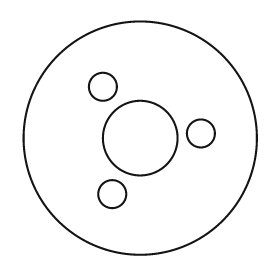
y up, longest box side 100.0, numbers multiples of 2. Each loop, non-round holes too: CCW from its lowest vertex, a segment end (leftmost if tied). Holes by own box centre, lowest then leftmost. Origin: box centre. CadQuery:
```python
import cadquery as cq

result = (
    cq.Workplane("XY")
    .moveTo(0.0, 0.0)
    .circle(50.0)
    .moveTo(-12.0, -24.0)
    .circle(6.0)
    .moveTo(0.0, 0.0)
    .circle(16.0)
    .moveTo(26.0, 2.0)
    .circle(6.0)
    .moveTo(-16.0, 22.0)
    .circle(6.0)
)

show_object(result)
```